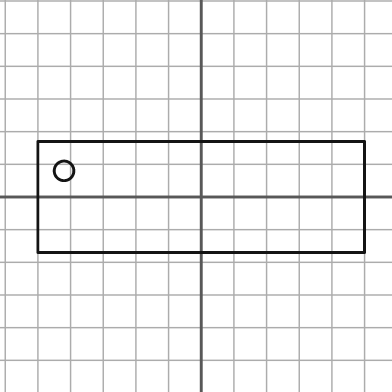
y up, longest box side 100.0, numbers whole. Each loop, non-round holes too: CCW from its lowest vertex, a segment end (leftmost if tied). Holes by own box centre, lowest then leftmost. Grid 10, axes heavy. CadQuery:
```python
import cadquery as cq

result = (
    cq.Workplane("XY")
    .moveTo(-50.0, -17.0)
    .lineTo(50.0, -17.0)
    .lineTo(50.0, 17.0)
    .lineTo(-50.0, 17.0)
    .close()
    .moveTo(-42.0, 8.0)
    .circle(3.0)
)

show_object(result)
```